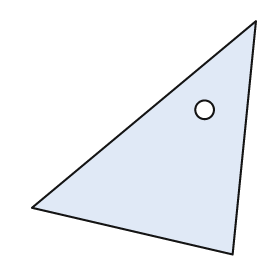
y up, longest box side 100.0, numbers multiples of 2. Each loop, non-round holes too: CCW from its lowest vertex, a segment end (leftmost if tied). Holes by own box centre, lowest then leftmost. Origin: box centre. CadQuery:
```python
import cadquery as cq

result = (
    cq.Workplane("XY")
    .moveTo(38.0, -50.0)
    .lineTo(48.0, 50.0)
    .lineTo(-48.0, -30.0)
    .close()
    .moveTo(26.0, 12.0)
    .circle(4.0)
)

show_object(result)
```